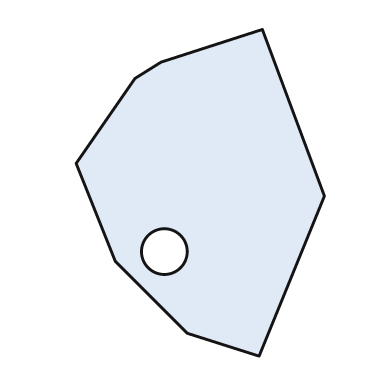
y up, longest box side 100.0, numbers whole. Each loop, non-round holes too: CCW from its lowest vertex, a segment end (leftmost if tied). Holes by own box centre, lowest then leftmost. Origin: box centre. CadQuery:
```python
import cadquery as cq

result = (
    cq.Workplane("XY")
    .moveTo(18.0, -50.0)
    .lineTo(38.0, -1.0)
    .lineTo(19.0, 50.0)
    .lineTo(-12.0, 40.0)
    .lineTo(-20.0, 35.0)
    .lineTo(-38.0, 9.0)
    .lineTo(-26.0, -21.0)
    .lineTo(-4.0, -43.0)
    .close()
    .moveTo(-11.0, -18.0)
    .circle(7.0)
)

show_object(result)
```